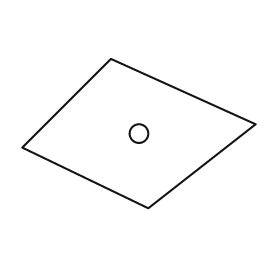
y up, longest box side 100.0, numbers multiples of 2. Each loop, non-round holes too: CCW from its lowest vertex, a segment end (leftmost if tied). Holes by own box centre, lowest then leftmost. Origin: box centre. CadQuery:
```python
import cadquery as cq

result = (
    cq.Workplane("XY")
    .moveTo(4.0, -32.0)
    .lineTo(50.0, 4.0)
    .lineTo(-12.0, 32.0)
    .lineTo(-50.0, -6.0)
    .close()
    .moveTo(0.0, 0.0)
    .circle(4.0)
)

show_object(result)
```